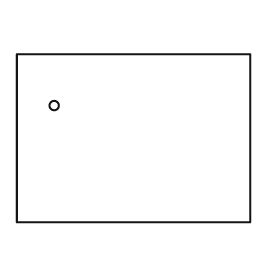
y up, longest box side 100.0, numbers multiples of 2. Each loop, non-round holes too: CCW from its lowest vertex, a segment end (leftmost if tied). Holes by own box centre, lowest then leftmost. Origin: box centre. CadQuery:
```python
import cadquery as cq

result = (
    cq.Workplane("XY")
    .moveTo(-50.0, -36.0)
    .lineTo(50.0, -36.0)
    .lineTo(50.0, 36.0)
    .lineTo(-50.0, 36.0)
    .close()
    .moveTo(-34.0, 14.0)
    .circle(2.0)
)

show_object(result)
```